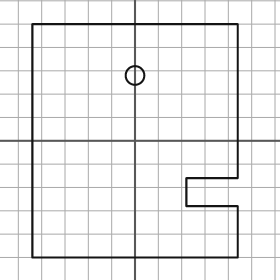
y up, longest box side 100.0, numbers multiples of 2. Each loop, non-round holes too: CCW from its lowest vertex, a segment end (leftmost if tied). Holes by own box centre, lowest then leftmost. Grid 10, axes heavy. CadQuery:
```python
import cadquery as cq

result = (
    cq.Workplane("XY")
    .moveTo(-44.0, -50.0)
    .lineTo(44.0, -50.0)
    .lineTo(44.0, -28.0)
    .lineTo(22.0, -28.0)
    .lineTo(22.0, -16.0)
    .lineTo(44.0, -16.0)
    .lineTo(44.0, 50.0)
    .lineTo(-44.0, 50.0)
    .close()
    .moveTo(0.0, 28.0)
    .circle(4.0)
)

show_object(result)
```